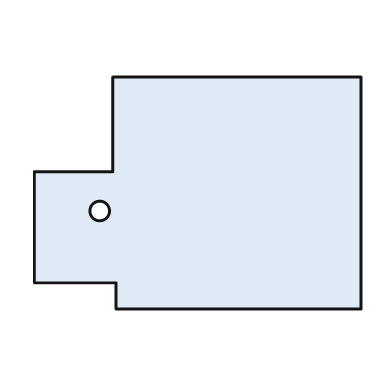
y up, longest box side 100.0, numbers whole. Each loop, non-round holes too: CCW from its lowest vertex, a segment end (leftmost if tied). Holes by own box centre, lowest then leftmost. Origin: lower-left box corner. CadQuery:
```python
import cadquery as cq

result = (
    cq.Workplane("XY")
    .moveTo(25.0, 0.0)
    .lineTo(100.0, 0.0)
    .lineTo(100.0, 71.0)
    .lineTo(24.0, 71.0)
    .lineTo(24.0, 42.0)
    .lineTo(0.0, 42.0)
    .lineTo(0.0, 8.0)
    .lineTo(25.0, 8.0)
    .close()
    .moveTo(20.0, 30.0)
    .circle(3.0)
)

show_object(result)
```